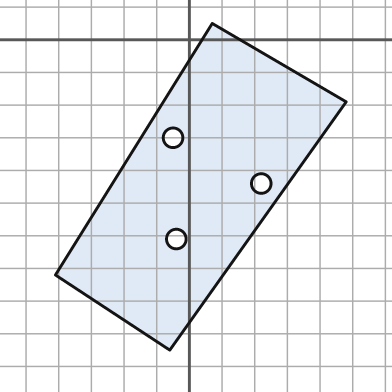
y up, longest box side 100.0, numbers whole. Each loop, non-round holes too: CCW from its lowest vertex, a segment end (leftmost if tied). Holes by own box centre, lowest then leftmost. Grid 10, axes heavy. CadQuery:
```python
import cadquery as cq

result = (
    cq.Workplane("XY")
    .moveTo(-6.0, -95.0)
    .lineTo(48.0, -19.0)
    .lineTo(7.0, 5.0)
    .lineTo(-41.0, -72.0)
    .close()
    .moveTo(-4.0, -61.0)
    .circle(3.0)
    .moveTo(22.0, -44.0)
    .circle(3.0)
    .moveTo(-5.0, -30.0)
    .circle(3.0)
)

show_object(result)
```